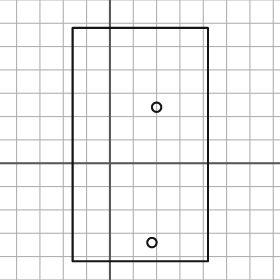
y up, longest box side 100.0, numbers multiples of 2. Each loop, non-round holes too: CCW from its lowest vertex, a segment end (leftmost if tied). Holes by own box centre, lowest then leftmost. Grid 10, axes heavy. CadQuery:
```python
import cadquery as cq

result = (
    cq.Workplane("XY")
    .moveTo(-16.0, -42.0)
    .lineTo(42.0, -42.0)
    .lineTo(42.0, 58.0)
    .lineTo(-16.0, 58.0)
    .close()
    .moveTo(18.0, -34.0)
    .circle(2.0)
    .moveTo(20.0, 24.0)
    .circle(2.0)
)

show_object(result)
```